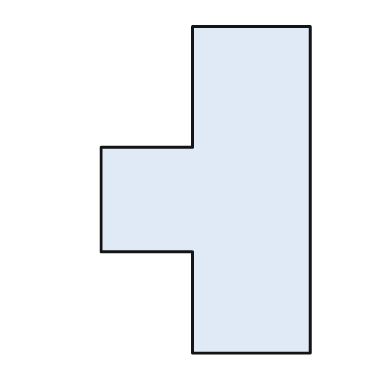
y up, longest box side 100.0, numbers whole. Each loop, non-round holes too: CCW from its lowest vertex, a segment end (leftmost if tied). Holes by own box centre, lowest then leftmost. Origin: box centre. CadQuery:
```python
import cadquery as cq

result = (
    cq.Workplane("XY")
    .moveTo(-4.0, -50.0)
    .lineTo(32.0, -50.0)
    .lineTo(32.0, 50.0)
    .lineTo(-4.0, 50.0)
    .lineTo(-4.0, 13.0)
    .lineTo(-32.0, 13.0)
    .lineTo(-32.0, -19.0)
    .lineTo(-4.0, -19.0)
    .close()
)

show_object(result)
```